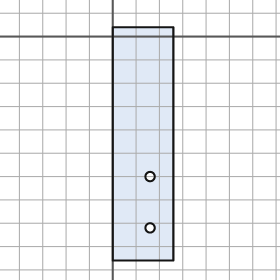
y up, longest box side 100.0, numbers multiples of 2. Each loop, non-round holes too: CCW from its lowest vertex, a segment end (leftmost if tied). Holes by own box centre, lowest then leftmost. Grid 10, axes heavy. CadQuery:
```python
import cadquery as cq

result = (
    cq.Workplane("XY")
    .moveTo(0.0, -96.0)
    .lineTo(26.0, -96.0)
    .lineTo(26.0, 4.0)
    .lineTo(0.0, 4.0)
    .close()
    .moveTo(16.0, -82.0)
    .circle(2.0)
    .moveTo(16.0, -60.0)
    .circle(2.0)
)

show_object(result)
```